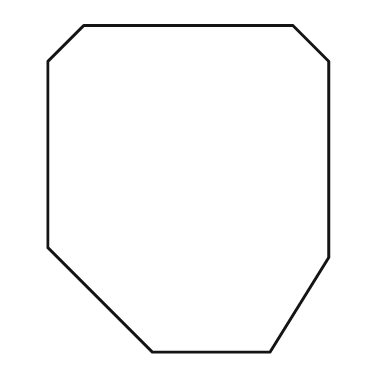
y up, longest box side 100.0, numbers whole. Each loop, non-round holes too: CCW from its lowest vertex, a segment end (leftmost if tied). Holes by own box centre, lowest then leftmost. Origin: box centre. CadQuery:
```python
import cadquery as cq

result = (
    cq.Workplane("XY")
    .moveTo(-11.0, -50.0)
    .lineTo(25.0, -50.0)
    .lineTo(43.0, -21.0)
    .lineTo(43.0, 39.0)
    .lineTo(32.0, 50.0)
    .lineTo(-32.0, 50.0)
    .lineTo(-43.0, 39.0)
    .lineTo(-43.0, -18.0)
    .close()
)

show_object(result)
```